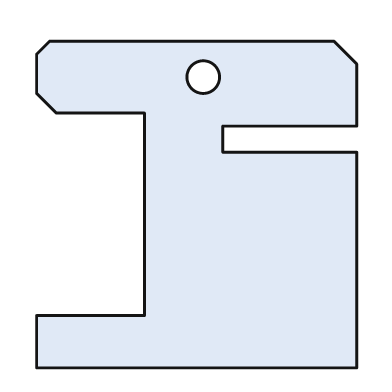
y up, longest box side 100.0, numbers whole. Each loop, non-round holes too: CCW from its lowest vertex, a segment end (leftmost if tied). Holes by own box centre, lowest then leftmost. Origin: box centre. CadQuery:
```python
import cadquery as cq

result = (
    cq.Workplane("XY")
    .moveTo(-49.0, -50.0)
    .lineTo(49.0, -50.0)
    .lineTo(49.0, 16.0)
    .lineTo(8.0, 16.0)
    .lineTo(8.0, 24.0)
    .lineTo(49.0, 24.0)
    .lineTo(49.0, 43.0)
    .lineTo(42.0, 50.0)
    .lineTo(-45.0, 50.0)
    .lineTo(-49.0, 46.0)
    .lineTo(-49.0, 34.0)
    .lineTo(-43.0, 28.0)
    .lineTo(-16.0, 28.0)
    .lineTo(-16.0, -34.0)
    .lineTo(-49.0, -34.0)
    .close()
    .moveTo(2.0, 39.0)
    .circle(5.0)
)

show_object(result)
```